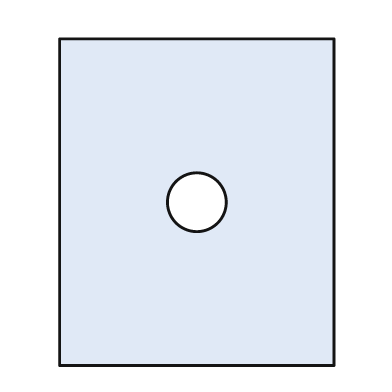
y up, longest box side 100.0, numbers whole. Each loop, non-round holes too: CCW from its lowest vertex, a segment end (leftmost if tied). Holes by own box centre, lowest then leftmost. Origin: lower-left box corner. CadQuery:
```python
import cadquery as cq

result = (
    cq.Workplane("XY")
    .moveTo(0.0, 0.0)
    .lineTo(84.0, 0.0)
    .lineTo(84.0, 100.0)
    .lineTo(0.0, 100.0)
    .close()
    .moveTo(42.0, 50.0)
    .circle(9.0)
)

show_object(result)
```